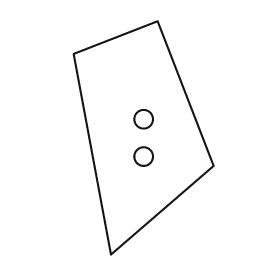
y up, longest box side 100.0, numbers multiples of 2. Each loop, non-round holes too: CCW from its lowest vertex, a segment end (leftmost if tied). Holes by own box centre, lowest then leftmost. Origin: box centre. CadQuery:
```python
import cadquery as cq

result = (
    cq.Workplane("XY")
    .moveTo(-14.0, -50.0)
    .lineTo(30.0, -12.0)
    .lineTo(6.0, 50.0)
    .lineTo(-30.0, 36.0)
    .close()
    .moveTo(0.0, -8.0)
    .circle(4.0)
    .moveTo(0.0, 8.0)
    .circle(4.0)
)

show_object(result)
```